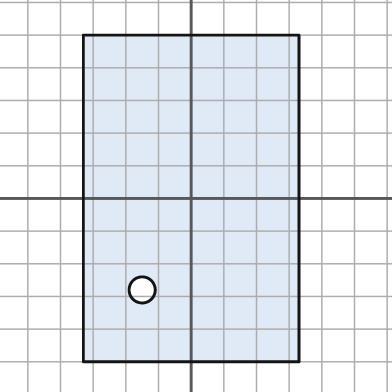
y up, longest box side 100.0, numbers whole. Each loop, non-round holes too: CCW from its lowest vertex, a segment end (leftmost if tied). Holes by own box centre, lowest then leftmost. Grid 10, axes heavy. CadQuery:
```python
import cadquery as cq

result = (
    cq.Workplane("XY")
    .moveTo(-33.0, -50.0)
    .lineTo(33.0, -50.0)
    .lineTo(33.0, 50.0)
    .lineTo(-33.0, 50.0)
    .close()
    .moveTo(-15.0, -28.0)
    .circle(4.0)
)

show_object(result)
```